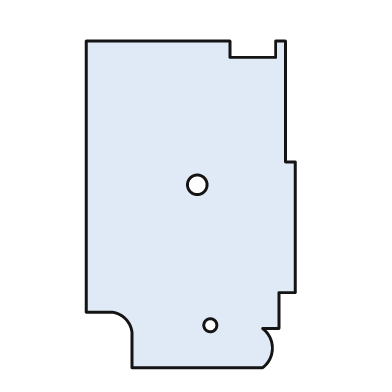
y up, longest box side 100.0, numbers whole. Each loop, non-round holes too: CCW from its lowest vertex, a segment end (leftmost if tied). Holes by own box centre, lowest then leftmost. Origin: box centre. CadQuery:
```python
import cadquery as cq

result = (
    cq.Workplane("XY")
    .moveTo(-18.0, -50.0)
    .lineTo(22.0, -50.0)
    .threePointArc((25.0, -44.0), (22.0, -38.0))
    .lineTo(27.0, -38.0)
    .lineTo(27.0, -27.0)
    .lineTo(32.0, -27.0)
    .lineTo(32.0, 13.0)
    .lineTo(29.0, 13.0)
    .lineTo(29.0, 50.0)
    .lineTo(26.0, 50.0)
    .lineTo(26.0, 45.0)
    .lineTo(12.0, 45.0)
    .lineTo(12.0, 50.0)
    .lineTo(-32.0, 50.0)
    .lineTo(-32.0, -33.0)
    .lineTo(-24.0, -33.0)
    .threePointArc((-20.0, -35.0), (-18.0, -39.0))
    .close()
    .moveTo(6.0, -37.0)
    .circle(2.0)
    .moveTo(2.0, 6.0)
    .circle(3.0)
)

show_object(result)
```